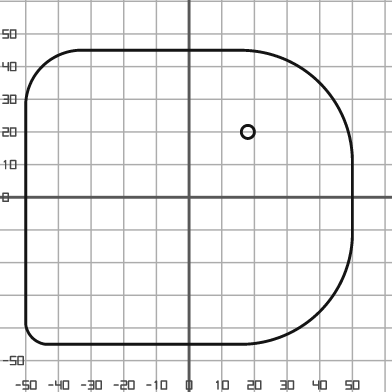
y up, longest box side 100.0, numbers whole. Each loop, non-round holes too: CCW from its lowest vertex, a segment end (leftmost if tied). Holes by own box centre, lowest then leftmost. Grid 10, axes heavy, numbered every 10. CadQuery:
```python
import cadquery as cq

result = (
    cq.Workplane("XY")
    .moveTo(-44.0, -45.0)
    .lineTo(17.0, -45.0)
    .threePointArc((40.0, -35.0), (50.0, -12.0))
    .lineTo(50.0, 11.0)
    .threePointArc((40.0, 35.0), (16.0, 45.0))
    .lineTo(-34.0, 45.0)
    .threePointArc((-45.0, 40.0), (-50.0, 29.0))
    .lineTo(-50.0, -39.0)
    .threePointArc((-48.0, -43.0), (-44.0, -45.0))
    .close()
    .moveTo(18.0, 20.0)
    .circle(2.0)
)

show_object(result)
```